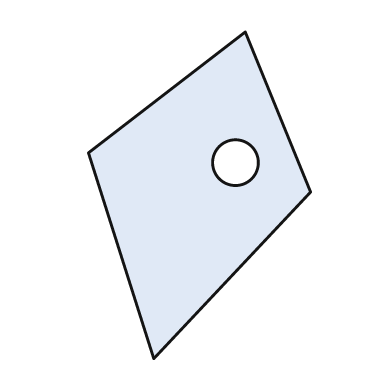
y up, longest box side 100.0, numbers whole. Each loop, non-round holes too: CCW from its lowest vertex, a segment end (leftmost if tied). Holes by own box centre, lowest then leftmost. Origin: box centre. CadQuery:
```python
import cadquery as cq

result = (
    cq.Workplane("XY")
    .moveTo(-14.0, -50.0)
    .lineTo(34.0, 1.0)
    .lineTo(14.0, 50.0)
    .lineTo(-34.0, 13.0)
    .close()
    .moveTo(11.0, 10.0)
    .circle(7.0)
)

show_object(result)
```